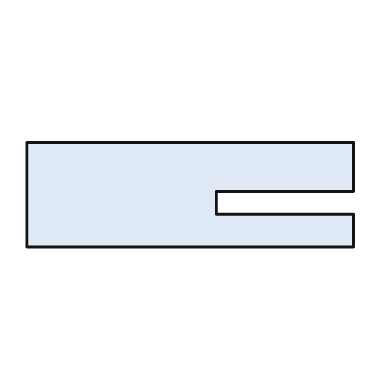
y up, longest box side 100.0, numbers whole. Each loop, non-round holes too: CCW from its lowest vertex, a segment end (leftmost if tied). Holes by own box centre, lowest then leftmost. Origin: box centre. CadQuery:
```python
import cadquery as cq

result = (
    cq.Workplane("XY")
    .moveTo(-50.0, -16.0)
    .lineTo(50.0, -16.0)
    .lineTo(50.0, -6.0)
    .lineTo(8.0, -6.0)
    .lineTo(8.0, 1.0)
    .lineTo(50.0, 1.0)
    .lineTo(50.0, 16.0)
    .lineTo(-50.0, 16.0)
    .close()
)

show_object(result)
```